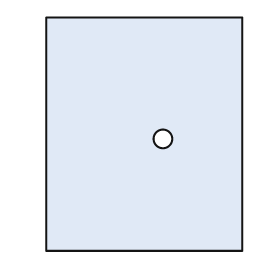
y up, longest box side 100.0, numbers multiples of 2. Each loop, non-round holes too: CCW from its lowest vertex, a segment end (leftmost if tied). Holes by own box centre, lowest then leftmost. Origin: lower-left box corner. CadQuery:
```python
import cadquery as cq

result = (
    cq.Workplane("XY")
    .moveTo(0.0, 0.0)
    .lineTo(84.0, 0.0)
    .lineTo(84.0, 100.0)
    .lineTo(0.0, 100.0)
    .close()
    .moveTo(50.0, 48.0)
    .circle(4.0)
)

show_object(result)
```